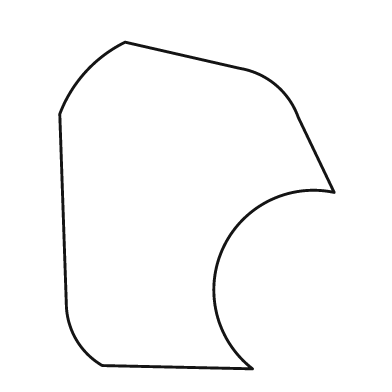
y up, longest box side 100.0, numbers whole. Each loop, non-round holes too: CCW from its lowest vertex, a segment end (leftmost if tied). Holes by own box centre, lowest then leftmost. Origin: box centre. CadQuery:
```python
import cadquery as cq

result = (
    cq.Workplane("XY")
    .moveTo(17.0, -50.0)
    .threePointArc((8.0, -13.0), (42.0, 4.0))
    .lineTo(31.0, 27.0)
    .threePointArc((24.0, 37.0), (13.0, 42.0))
    .lineTo(-22.0, 50.0)
    .threePointArc((-34.0, 41.0), (-42.0, 28.0))
    .lineTo(-40.0, -30.0)
    .threePointArc((-37.0, -41.0), (-29.0, -49.0))
    .close()
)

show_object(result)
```